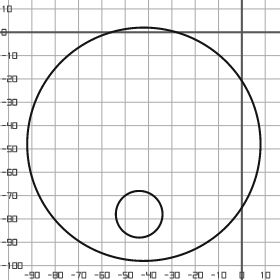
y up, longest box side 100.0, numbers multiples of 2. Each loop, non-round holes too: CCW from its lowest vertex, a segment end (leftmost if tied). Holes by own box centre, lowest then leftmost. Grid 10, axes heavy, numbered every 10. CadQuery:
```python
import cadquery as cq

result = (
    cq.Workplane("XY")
    .moveTo(-42.0, -48.0)
    .circle(50.0)
    .moveTo(-44.0, -78.0)
    .circle(10.0)
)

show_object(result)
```